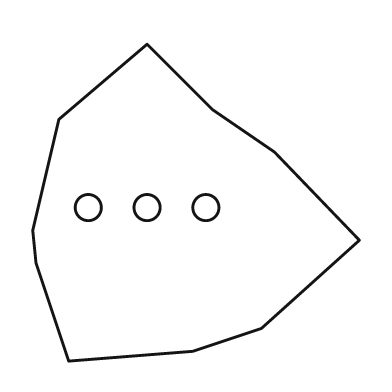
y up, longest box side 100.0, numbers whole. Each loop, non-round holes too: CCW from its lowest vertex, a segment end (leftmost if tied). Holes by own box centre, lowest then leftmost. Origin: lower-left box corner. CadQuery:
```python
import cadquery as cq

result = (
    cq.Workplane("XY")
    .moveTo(11.0, 0.0)
    .lineTo(49.0, 3.0)
    .lineTo(70.0, 10.0)
    .lineTo(100.0, 37.0)
    .lineTo(74.0, 64.0)
    .lineTo(55.0, 77.0)
    .lineTo(35.0, 97.0)
    .lineTo(8.0, 74.0)
    .lineTo(0.0, 40.0)
    .lineTo(1.0, 30.0)
    .close()
    .moveTo(17.0, 47.0)
    .circle(4.0)
    .moveTo(35.0, 47.0)
    .circle(4.0)
    .moveTo(53.0, 47.0)
    .circle(4.0)
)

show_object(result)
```